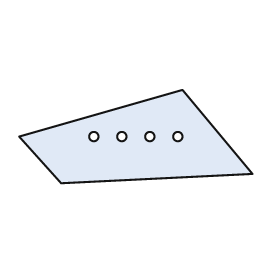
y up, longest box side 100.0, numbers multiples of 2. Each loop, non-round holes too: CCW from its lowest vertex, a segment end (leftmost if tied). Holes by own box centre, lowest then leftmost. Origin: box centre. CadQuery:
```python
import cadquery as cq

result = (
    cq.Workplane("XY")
    .moveTo(-32.0, -20.0)
    .lineTo(50.0, -16.0)
    .lineTo(20.0, 20.0)
    .lineTo(-50.0, 0.0)
    .close()
    .moveTo(-18.0, 0.0)
    .circle(2.0)
    .moveTo(-6.0, 0.0)
    .circle(2.0)
    .moveTo(6.0, 0.0)
    .circle(2.0)
    .moveTo(18.0, 0.0)
    .circle(2.0)
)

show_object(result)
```